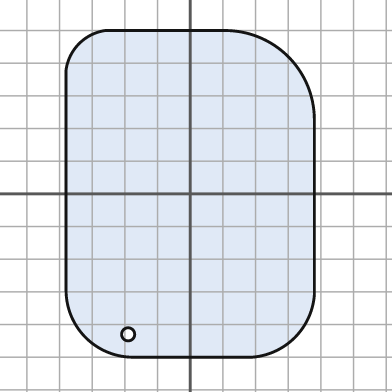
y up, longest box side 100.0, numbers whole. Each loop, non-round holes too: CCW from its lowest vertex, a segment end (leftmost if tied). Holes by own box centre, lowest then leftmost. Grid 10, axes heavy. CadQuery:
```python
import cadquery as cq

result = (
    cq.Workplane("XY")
    .moveTo(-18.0, -50.0)
    .lineTo(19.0, -50.0)
    .threePointArc((32.0, -44.0), (38.0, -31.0))
    .lineTo(38.0, 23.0)
    .threePointArc((30.0, 42.0), (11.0, 50.0))
    .lineTo(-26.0, 50.0)
    .threePointArc((-34.0, 46.0), (-38.0, 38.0))
    .lineTo(-38.0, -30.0)
    .threePointArc((-32.0, -44.0), (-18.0, -50.0))
    .close()
    .moveTo(-19.0, -43.0)
    .circle(2.0)
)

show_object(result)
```